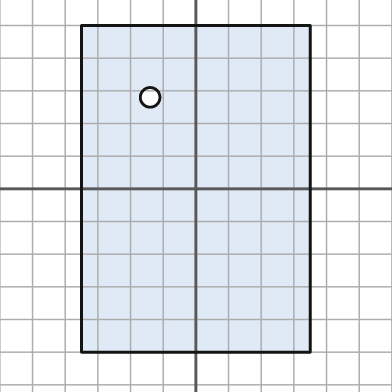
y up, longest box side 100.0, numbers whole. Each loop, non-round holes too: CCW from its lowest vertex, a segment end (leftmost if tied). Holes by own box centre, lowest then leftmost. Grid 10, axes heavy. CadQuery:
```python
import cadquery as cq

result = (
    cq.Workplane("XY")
    .moveTo(-35.0, -50.0)
    .lineTo(35.0, -50.0)
    .lineTo(35.0, 50.0)
    .lineTo(-35.0, 50.0)
    .close()
    .moveTo(-14.0, 28.0)
    .circle(3.0)
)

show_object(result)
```